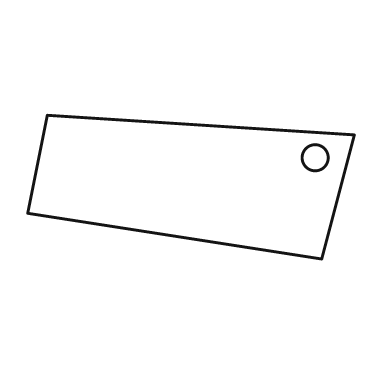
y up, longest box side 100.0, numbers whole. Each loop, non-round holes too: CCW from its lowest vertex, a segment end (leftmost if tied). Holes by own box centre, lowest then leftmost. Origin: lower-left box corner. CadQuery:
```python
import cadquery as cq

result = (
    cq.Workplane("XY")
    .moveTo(90.0, 0.0)
    .lineTo(100.0, 38.0)
    .lineTo(6.0, 44.0)
    .lineTo(0.0, 14.0)
    .close()
    .moveTo(88.0, 31.0)
    .circle(4.0)
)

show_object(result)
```